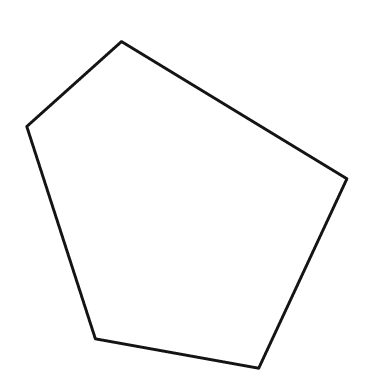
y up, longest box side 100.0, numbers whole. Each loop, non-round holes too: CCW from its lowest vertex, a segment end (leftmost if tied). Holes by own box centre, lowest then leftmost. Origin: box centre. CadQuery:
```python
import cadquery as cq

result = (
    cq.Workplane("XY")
    .moveTo(22.0, -50.0)
    .lineTo(49.0, 8.0)
    .lineTo(-20.0, 50.0)
    .lineTo(-49.0, 24.0)
    .lineTo(-28.0, -41.0)
    .close()
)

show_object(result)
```